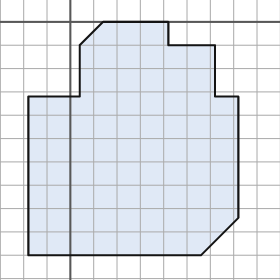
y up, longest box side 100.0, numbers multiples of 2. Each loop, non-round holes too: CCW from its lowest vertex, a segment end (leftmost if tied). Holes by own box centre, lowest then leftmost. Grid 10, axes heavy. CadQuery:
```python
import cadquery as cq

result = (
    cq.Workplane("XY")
    .moveTo(-18.0, -100.0)
    .lineTo(56.0, -100.0)
    .lineTo(72.0, -84.0)
    .lineTo(72.0, -32.0)
    .lineTo(62.0, -32.0)
    .lineTo(62.0, -10.0)
    .lineTo(42.0, -10.0)
    .lineTo(42.0, 0.0)
    .lineTo(14.0, 0.0)
    .lineTo(4.0, -10.0)
    .lineTo(4.0, -32.0)
    .lineTo(-18.0, -32.0)
    .close()
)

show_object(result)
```